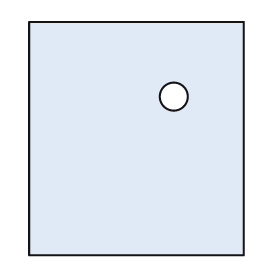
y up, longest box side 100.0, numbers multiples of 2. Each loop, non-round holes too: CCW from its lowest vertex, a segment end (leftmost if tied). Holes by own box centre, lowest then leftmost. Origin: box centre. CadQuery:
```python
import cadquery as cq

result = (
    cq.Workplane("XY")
    .moveTo(-46.0, -50.0)
    .lineTo(46.0, -50.0)
    .lineTo(46.0, 50.0)
    .lineTo(-46.0, 50.0)
    .close()
    .moveTo(16.0, 18.0)
    .circle(6.0)
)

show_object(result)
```